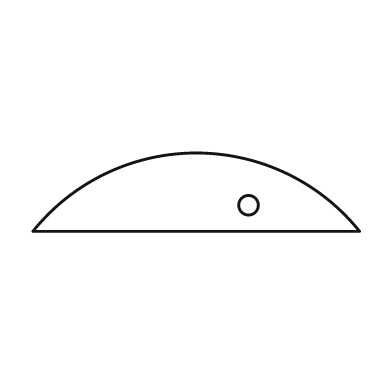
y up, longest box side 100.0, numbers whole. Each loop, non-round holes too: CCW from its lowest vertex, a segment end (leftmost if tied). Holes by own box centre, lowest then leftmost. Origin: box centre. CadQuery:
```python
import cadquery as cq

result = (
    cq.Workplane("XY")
    .moveTo(-50.0, -12.0)
    .lineTo(50.0, -12.0)
    .threePointArc((0.0, 12.0), (-50.0, -12.0))
    .close()
    .moveTo(16.0, -4.0)
    .circle(3.0)
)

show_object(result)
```